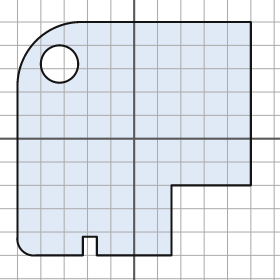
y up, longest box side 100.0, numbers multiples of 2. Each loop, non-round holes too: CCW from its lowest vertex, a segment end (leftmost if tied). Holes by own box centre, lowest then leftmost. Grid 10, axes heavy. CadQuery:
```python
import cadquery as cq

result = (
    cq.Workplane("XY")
    .moveTo(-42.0, -50.0)
    .lineTo(-22.0, -50.0)
    .lineTo(-22.0, -42.0)
    .lineTo(-16.0, -42.0)
    .lineTo(-16.0, -50.0)
    .lineTo(16.0, -50.0)
    .lineTo(16.0, -20.0)
    .lineTo(50.0, -20.0)
    .lineTo(50.0, 50.0)
    .lineTo(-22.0, 50.0)
    .threePointArc((-42.0, 42.0), (-50.0, 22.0))
    .lineTo(-50.0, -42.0)
    .threePointArc((-48.0, -48.0), (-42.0, -50.0))
    .close()
    .moveTo(-32.0, 32.0)
    .circle(8.0)
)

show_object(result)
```